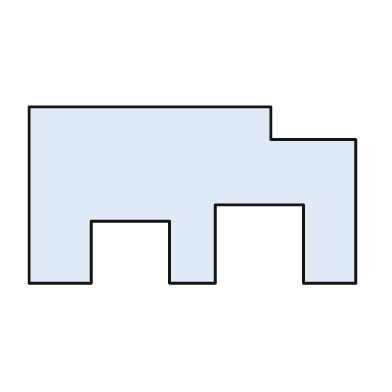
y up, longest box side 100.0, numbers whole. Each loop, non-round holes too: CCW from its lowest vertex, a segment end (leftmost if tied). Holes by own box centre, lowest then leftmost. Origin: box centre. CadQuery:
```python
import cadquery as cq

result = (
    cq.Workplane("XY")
    .moveTo(-50.0, -27.0)
    .lineTo(-31.0, -27.0)
    .lineTo(-31.0, -8.0)
    .lineTo(-7.0, -8.0)
    .lineTo(-7.0, -27.0)
    .lineTo(7.0, -27.0)
    .lineTo(7.0, -3.0)
    .lineTo(34.0, -3.0)
    .lineTo(34.0, -27.0)
    .lineTo(50.0, -27.0)
    .lineTo(50.0, 17.0)
    .lineTo(24.0, 17.0)
    .lineTo(24.0, 27.0)
    .lineTo(-50.0, 27.0)
    .close()
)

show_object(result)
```